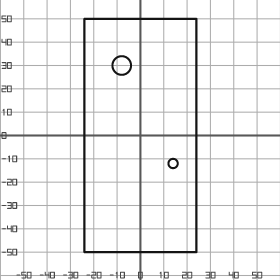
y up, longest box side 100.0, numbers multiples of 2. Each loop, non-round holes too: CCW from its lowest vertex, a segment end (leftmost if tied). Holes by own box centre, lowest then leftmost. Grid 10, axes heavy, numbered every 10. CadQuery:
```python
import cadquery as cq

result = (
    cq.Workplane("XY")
    .moveTo(-24.0, -50.0)
    .lineTo(24.0, -50.0)
    .lineTo(24.0, 50.0)
    .lineTo(-24.0, 50.0)
    .close()
    .moveTo(14.0, -12.0)
    .circle(2.0)
    .moveTo(-8.0, 30.0)
    .circle(4.0)
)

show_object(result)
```